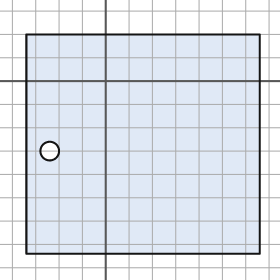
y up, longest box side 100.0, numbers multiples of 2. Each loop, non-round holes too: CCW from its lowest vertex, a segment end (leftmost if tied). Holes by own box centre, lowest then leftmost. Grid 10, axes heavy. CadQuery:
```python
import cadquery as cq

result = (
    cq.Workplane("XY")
    .moveTo(-34.0, -74.0)
    .lineTo(66.0, -74.0)
    .lineTo(66.0, 20.0)
    .lineTo(-34.0, 20.0)
    .close()
    .moveTo(-24.0, -30.0)
    .circle(4.0)
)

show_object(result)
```